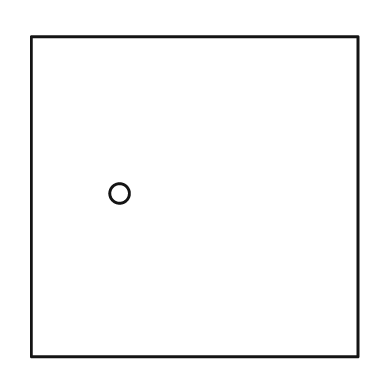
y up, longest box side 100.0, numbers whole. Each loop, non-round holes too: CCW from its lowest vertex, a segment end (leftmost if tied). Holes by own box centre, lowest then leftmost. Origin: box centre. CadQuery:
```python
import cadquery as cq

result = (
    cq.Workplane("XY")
    .moveTo(-50.0, -49.0)
    .lineTo(50.0, -49.0)
    .lineTo(50.0, 49.0)
    .lineTo(-50.0, 49.0)
    .close()
    .moveTo(-23.0, 1.0)
    .circle(3.0)
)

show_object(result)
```